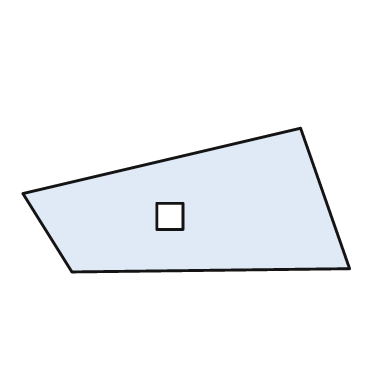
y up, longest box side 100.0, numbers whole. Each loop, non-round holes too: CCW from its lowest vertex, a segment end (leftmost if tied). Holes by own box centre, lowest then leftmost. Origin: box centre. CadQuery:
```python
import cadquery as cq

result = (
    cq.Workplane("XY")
    .moveTo(-35.0, -22.0)
    .lineTo(50.0, -21.0)
    .lineTo(35.0, 22.0)
    .lineTo(-50.0, 2.0)
    .close()
    .moveTo(-9.0, -9.0)
    .lineTo(-1.0, -9.0)
    .lineTo(-1.0, -1.0)
    .lineTo(-9.0, -1.0)
    .close()
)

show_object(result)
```